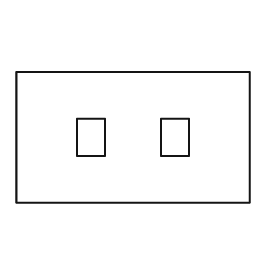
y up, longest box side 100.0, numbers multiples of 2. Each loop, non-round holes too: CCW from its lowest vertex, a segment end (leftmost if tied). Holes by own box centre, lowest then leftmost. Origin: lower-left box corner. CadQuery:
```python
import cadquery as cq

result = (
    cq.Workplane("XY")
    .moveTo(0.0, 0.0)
    .lineTo(100.0, 0.0)
    .lineTo(100.0, 56.0)
    .lineTo(0.0, 56.0)
    .close()
    .moveTo(26.0, 20.0)
    .lineTo(38.0, 20.0)
    .lineTo(38.0, 36.0)
    .lineTo(26.0, 36.0)
    .close()
    .moveTo(62.0, 20.0)
    .lineTo(74.0, 20.0)
    .lineTo(74.0, 36.0)
    .lineTo(62.0, 36.0)
    .close()
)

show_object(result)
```